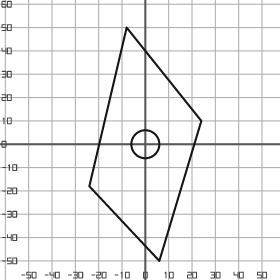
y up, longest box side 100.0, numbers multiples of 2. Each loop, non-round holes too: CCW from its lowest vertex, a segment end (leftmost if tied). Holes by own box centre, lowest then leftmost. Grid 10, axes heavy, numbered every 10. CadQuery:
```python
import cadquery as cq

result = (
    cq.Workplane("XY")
    .moveTo(6.0, -50.0)
    .lineTo(24.0, 10.0)
    .lineTo(-8.0, 50.0)
    .lineTo(-24.0, -18.0)
    .close()
    .moveTo(0.0, 0.0)
    .circle(6.0)
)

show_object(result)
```